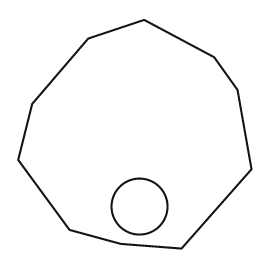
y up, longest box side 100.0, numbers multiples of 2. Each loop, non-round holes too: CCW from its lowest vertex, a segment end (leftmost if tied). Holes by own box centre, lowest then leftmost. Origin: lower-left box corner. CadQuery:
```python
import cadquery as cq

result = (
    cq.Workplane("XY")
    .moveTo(70.0, 0.0)
    .lineTo(100.0, 34.0)
    .lineTo(94.0, 68.0)
    .lineTo(84.0, 82.0)
    .lineTo(54.0, 98.0)
    .lineTo(30.0, 90.0)
    .lineTo(6.0, 62.0)
    .lineTo(0.0, 38.0)
    .lineTo(22.0, 8.0)
    .lineTo(44.0, 2.0)
    .close()
    .moveTo(52.0, 18.0)
    .circle(12.0)
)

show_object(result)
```